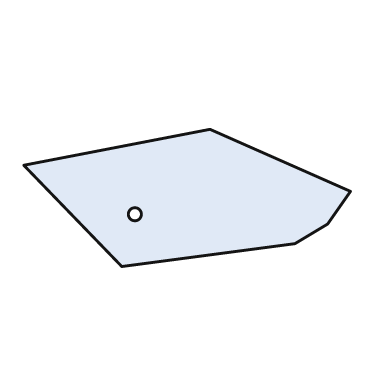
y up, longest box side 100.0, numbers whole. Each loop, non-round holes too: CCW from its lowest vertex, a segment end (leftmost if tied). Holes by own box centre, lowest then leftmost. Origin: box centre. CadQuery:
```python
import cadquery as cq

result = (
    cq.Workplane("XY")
    .moveTo(-20.0, -21.0)
    .lineTo(33.0, -14.0)
    .lineTo(43.0, -8.0)
    .lineTo(50.0, 2.0)
    .lineTo(7.0, 21.0)
    .lineTo(-50.0, 10.0)
    .close()
    .moveTo(-16.0, -5.0)
    .circle(2.0)
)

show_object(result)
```